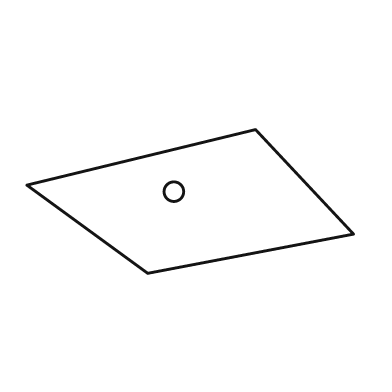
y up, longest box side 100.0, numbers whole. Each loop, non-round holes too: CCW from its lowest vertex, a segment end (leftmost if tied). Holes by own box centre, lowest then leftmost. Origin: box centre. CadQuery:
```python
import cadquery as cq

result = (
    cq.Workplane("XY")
    .moveTo(-13.0, -22.0)
    .lineTo(50.0, -10.0)
    .lineTo(20.0, 22.0)
    .lineTo(-50.0, 5.0)
    .close()
    .moveTo(-5.0, 3.0)
    .circle(3.0)
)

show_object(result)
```